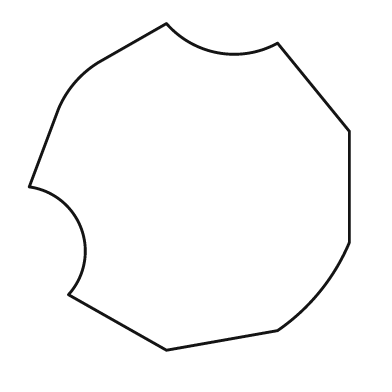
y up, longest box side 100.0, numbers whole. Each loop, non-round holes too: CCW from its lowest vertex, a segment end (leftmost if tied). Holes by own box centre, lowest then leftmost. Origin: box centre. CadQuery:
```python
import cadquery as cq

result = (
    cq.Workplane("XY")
    .moveTo(-7.0, -50.0)
    .lineTo(27.0, -44.0)
    .threePointArc((40.0, -32.0), (49.0, -17.0))
    .lineTo(49.0, 17.0)
    .lineTo(27.0, 44.0)
    .threePointArc((9.0, 41.0), (-7.0, 50.0))
    .lineTo(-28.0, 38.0)
    .threePointArc((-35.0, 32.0), (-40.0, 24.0))
    .lineTo(-49.0, 0.0)
    .threePointArc((-33.0, -13.0), (-37.0, -33.0))
    .close()
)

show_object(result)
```